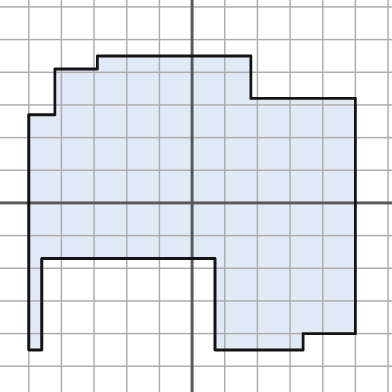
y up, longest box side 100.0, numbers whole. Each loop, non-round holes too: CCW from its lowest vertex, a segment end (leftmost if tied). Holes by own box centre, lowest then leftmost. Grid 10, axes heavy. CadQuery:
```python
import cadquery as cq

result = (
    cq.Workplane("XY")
    .moveTo(-50.0, -45.0)
    .lineTo(-46.0, -45.0)
    .lineTo(-46.0, -17.0)
    .lineTo(7.0, -17.0)
    .lineTo(7.0, -45.0)
    .lineTo(34.0, -45.0)
    .lineTo(34.0, -40.0)
    .lineTo(50.0, -40.0)
    .lineTo(50.0, 32.0)
    .lineTo(18.0, 32.0)
    .lineTo(18.0, 45.0)
    .lineTo(-29.0, 45.0)
    .lineTo(-29.0, 41.0)
    .lineTo(-42.0, 41.0)
    .lineTo(-42.0, 27.0)
    .lineTo(-50.0, 27.0)
    .close()
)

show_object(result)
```